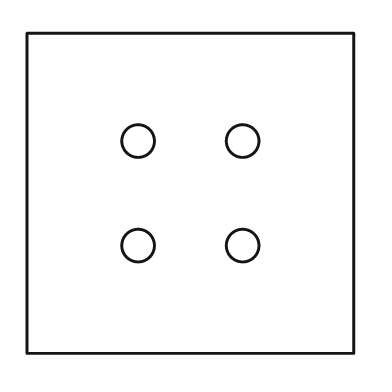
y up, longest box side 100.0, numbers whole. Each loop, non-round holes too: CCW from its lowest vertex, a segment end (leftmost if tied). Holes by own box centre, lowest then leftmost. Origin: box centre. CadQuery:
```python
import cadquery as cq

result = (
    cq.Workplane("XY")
    .moveTo(-50.0, -49.0)
    .lineTo(50.0, -49.0)
    .lineTo(50.0, 49.0)
    .lineTo(-50.0, 49.0)
    .close()
    .moveTo(-16.0, -16.0)
    .circle(5.0)
    .moveTo(16.0, -16.0)
    .circle(5.0)
    .moveTo(-16.0, 16.0)
    .circle(5.0)
    .moveTo(16.0, 16.0)
    .circle(5.0)
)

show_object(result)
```